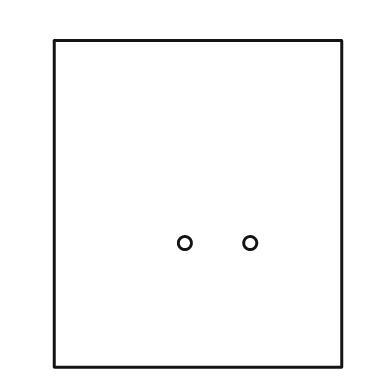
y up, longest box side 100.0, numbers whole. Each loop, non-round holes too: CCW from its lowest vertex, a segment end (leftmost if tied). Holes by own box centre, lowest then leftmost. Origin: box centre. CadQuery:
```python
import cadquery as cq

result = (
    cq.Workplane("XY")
    .moveTo(-44.0, -50.0)
    .lineTo(44.0, -50.0)
    .lineTo(44.0, 50.0)
    .lineTo(-44.0, 50.0)
    .close()
    .moveTo(-4.0, -12.0)
    .circle(2.0)
    .moveTo(16.0, -12.0)
    .circle(2.0)
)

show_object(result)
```